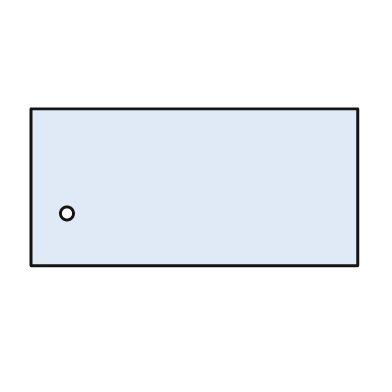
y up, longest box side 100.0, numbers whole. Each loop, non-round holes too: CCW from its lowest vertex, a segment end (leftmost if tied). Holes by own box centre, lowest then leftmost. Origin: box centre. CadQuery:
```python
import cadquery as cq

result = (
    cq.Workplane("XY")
    .moveTo(-50.0, -24.0)
    .lineTo(50.0, -24.0)
    .lineTo(50.0, 24.0)
    .lineTo(-50.0, 24.0)
    .close()
    .moveTo(-39.0, -8.0)
    .circle(2.0)
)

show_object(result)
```